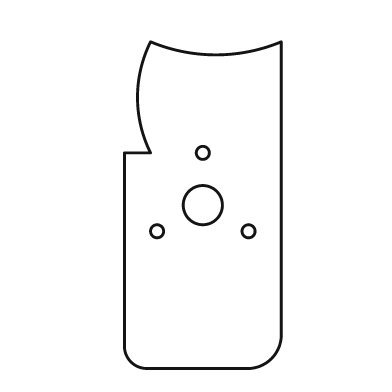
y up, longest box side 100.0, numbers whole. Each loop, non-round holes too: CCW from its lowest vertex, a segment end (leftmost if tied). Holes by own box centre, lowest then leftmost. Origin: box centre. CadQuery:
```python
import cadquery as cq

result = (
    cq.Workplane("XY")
    .moveTo(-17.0, -50.0)
    .lineTo(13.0, -50.0)
    .threePointArc((21.0, -47.0), (24.0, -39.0))
    .lineTo(24.0, 50.0)
    .threePointArc((4.0, 46.0), (-16.0, 50.0))
    .threePointArc((-20.0, 33.0), (-16.0, 16.0))
    .lineTo(-24.0, 16.0)
    .lineTo(-24.0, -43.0)
    .threePointArc((-22.0, -48.0), (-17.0, -50.0))
    .close()
    .moveTo(-14.0, -8.0)
    .circle(2.0)
    .moveTo(14.0, -8.0)
    .circle(2.0)
    .moveTo(0.0, 0.0)
    .circle(6.0)
    .moveTo(0.0, 16.0)
    .circle(2.0)
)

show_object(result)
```